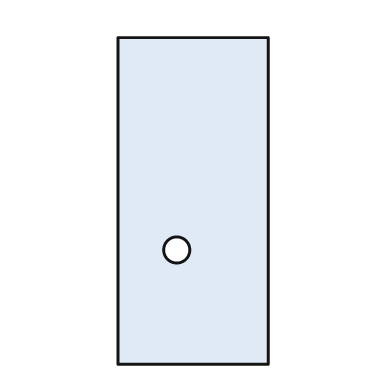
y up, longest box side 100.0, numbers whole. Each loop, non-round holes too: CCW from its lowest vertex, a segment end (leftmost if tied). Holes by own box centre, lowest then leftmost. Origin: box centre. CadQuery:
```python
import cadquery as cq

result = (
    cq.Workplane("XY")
    .moveTo(-23.0, -50.0)
    .lineTo(23.0, -50.0)
    .lineTo(23.0, 50.0)
    .lineTo(-23.0, 50.0)
    .close()
    .moveTo(-5.0, -15.0)
    .circle(4.0)
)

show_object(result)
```